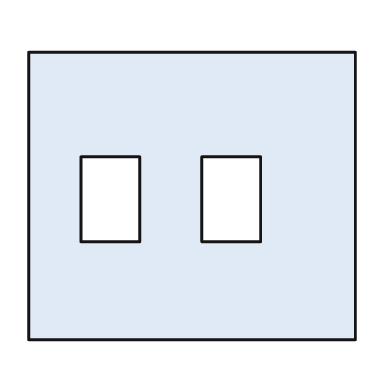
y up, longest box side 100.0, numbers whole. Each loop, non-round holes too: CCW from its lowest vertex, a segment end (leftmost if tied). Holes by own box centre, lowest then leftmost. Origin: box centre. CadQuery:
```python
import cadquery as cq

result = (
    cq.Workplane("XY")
    .moveTo(-50.0, -44.0)
    .lineTo(50.0, -44.0)
    .lineTo(50.0, 44.0)
    .lineTo(-50.0, 44.0)
    .close()
    .moveTo(-34.0, -14.0)
    .lineTo(-16.0, -14.0)
    .lineTo(-16.0, 12.0)
    .lineTo(-34.0, 12.0)
    .close()
    .moveTo(3.0, -14.0)
    .lineTo(21.0, -14.0)
    .lineTo(21.0, 12.0)
    .lineTo(3.0, 12.0)
    .close()
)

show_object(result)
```